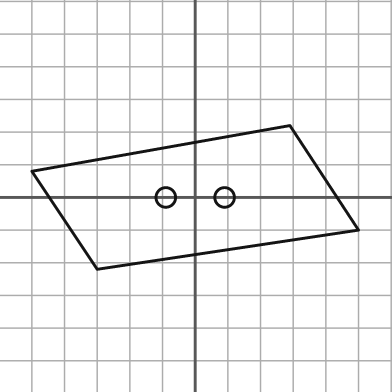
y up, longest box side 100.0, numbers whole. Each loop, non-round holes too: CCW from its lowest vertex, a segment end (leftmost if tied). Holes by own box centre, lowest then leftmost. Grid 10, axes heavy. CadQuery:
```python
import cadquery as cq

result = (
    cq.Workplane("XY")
    .moveTo(-30.0, -22.0)
    .lineTo(50.0, -10.0)
    .lineTo(29.0, 22.0)
    .lineTo(-50.0, 8.0)
    .close()
    .moveTo(-9.0, 0.0)
    .circle(3.0)
    .moveTo(9.0, 0.0)
    .circle(3.0)
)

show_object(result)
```